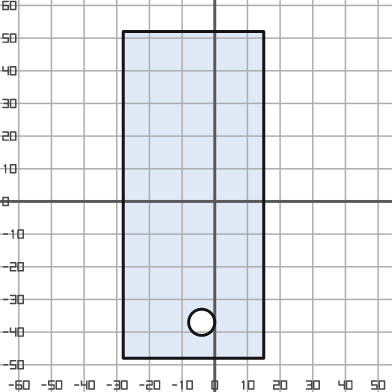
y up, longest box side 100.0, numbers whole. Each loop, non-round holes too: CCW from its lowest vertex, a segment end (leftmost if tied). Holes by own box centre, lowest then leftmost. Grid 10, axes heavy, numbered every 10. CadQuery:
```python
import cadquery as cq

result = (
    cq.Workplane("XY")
    .moveTo(-28.0, -48.0)
    .lineTo(15.0, -48.0)
    .lineTo(15.0, 52.0)
    .lineTo(-28.0, 52.0)
    .close()
    .moveTo(-4.0, -37.0)
    .circle(4.0)
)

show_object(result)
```